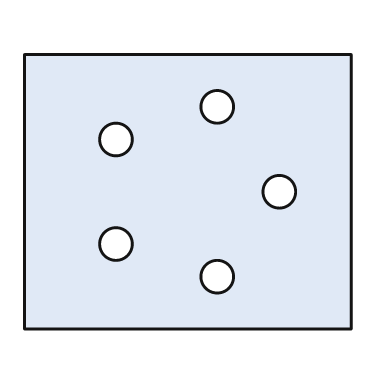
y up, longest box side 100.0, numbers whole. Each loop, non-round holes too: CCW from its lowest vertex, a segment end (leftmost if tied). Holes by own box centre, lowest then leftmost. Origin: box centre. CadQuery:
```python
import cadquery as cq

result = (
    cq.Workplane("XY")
    .moveTo(-50.0, -42.0)
    .lineTo(50.0, -42.0)
    .lineTo(50.0, 42.0)
    .lineTo(-50.0, 42.0)
    .close()
    .moveTo(9.0, -26.0)
    .circle(5.0)
    .moveTo(-22.0, -16.0)
    .circle(5.0)
    .moveTo(28.0, 0.0)
    .circle(5.0)
    .moveTo(-22.0, 16.0)
    .circle(5.0)
    .moveTo(9.0, 26.0)
    .circle(5.0)
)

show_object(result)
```